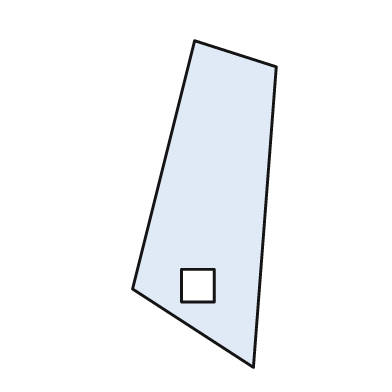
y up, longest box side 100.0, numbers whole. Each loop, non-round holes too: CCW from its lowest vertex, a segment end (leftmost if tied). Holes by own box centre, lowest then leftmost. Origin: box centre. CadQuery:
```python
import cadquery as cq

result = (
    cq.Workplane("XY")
    .moveTo(15.0, -50.0)
    .lineTo(22.0, 42.0)
    .lineTo(-3.0, 50.0)
    .lineTo(-22.0, -26.0)
    .close()
    .moveTo(-7.0, -30.0)
    .lineTo(3.0, -30.0)
    .lineTo(3.0, -20.0)
    .lineTo(-7.0, -20.0)
    .close()
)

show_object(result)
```